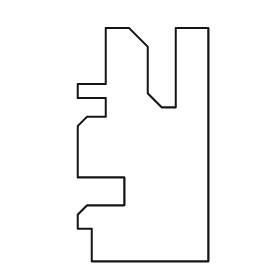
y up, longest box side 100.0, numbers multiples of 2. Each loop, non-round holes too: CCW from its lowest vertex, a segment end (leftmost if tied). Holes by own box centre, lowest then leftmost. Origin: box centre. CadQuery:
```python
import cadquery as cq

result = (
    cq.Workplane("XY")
    .moveTo(-22.0, -50.0)
    .lineTo(28.0, -50.0)
    .lineTo(28.0, 50.0)
    .lineTo(14.0, 50.0)
    .lineTo(14.0, 16.0)
    .lineTo(8.0, 16.0)
    .lineTo(2.0, 22.0)
    .lineTo(2.0, 42.0)
    .lineTo(-6.0, 50.0)
    .lineTo(-16.0, 50.0)
    .lineTo(-16.0, 26.0)
    .lineTo(-28.0, 26.0)
    .lineTo(-28.0, 20.0)
    .lineTo(-16.0, 20.0)
    .lineTo(-16.0, 12.0)
    .lineTo(-24.0, 12.0)
    .lineTo(-28.0, 8.0)
    .lineTo(-28.0, -14.0)
    .lineTo(-8.0, -14.0)
    .lineTo(-8.0, -26.0)
    .lineTo(-24.0, -26.0)
    .lineTo(-28.0, -30.0)
    .lineTo(-28.0, -36.0)
    .lineTo(-22.0, -36.0)
    .close()
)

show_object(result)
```